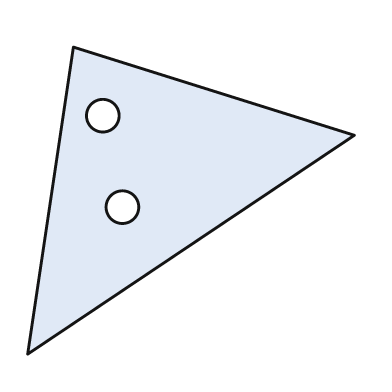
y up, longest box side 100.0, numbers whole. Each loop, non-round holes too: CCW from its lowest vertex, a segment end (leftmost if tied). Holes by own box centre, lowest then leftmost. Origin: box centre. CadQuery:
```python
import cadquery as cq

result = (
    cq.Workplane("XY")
    .moveTo(-50.0, -47.0)
    .lineTo(50.0, 20.0)
    .lineTo(-36.0, 47.0)
    .close()
    .moveTo(-21.0, -2.0)
    .circle(5.0)
    .moveTo(-27.0, 26.0)
    .circle(5.0)
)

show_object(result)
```